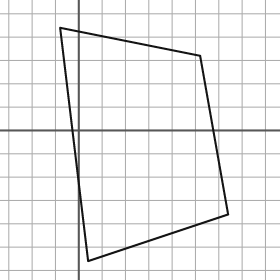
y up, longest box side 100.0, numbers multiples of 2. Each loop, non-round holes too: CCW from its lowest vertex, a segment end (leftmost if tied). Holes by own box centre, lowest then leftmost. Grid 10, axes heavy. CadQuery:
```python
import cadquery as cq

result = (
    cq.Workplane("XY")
    .moveTo(4.0, -56.0)
    .lineTo(64.0, -36.0)
    .lineTo(52.0, 32.0)
    .lineTo(-8.0, 44.0)
    .close()
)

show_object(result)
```